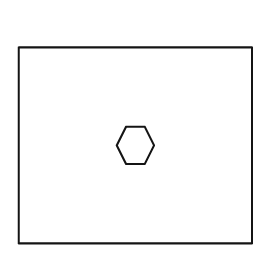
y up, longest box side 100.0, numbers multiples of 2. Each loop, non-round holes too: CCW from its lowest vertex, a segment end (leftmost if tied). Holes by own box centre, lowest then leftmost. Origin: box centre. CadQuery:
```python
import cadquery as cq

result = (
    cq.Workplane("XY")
    .moveTo(-50.0, -42.0)
    .lineTo(50.0, -42.0)
    .lineTo(50.0, 42.0)
    .lineTo(-50.0, 42.0)
    .close()
    .moveTo(-4.0, -8.0)
    .lineTo(4.0, -8.0)
    .lineTo(8.0, 0.0)
    .lineTo(4.0, 8.0)
    .lineTo(-4.0, 8.0)
    .lineTo(-8.0, 0.0)
    .close()
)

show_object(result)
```